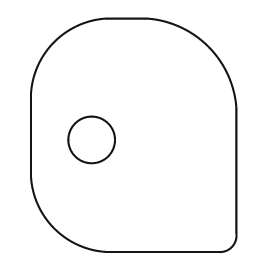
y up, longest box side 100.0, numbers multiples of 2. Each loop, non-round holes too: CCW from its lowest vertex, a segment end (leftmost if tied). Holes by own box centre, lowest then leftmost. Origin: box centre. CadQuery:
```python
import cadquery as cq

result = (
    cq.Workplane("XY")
    .moveTo(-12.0, -50.0)
    .lineTo(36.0, -50.0)
    .threePointArc((42.0, -48.0), (44.0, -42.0))
    .lineTo(44.0, 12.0)
    .threePointArc((32.0, 38.0), (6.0, 50.0))
    .lineTo(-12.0, 50.0)
    .threePointArc((-34.0, 40.0), (-44.0, 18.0))
    .lineTo(-44.0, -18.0)
    .threePointArc((-34.0, -40.0), (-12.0, -50.0))
    .close()
    .moveTo(-18.0, -2.0)
    .circle(10.0)
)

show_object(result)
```